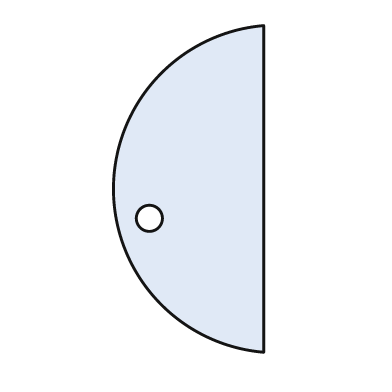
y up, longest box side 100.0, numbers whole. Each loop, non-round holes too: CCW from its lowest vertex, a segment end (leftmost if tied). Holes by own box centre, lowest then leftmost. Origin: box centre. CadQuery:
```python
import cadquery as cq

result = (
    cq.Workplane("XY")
    .moveTo(23.0, -50.0)
    .lineTo(23.0, 50.0)
    .threePointArc((-23.0, 0.0), (23.0, -50.0))
    .close()
    .moveTo(-12.0, -9.0)
    .circle(4.0)
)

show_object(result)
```